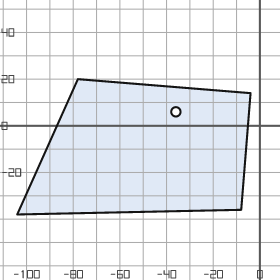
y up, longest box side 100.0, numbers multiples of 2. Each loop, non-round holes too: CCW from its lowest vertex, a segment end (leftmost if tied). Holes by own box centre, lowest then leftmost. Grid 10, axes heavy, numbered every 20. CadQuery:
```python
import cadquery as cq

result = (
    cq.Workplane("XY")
    .moveTo(-104.0, -38.0)
    .lineTo(-8.0, -36.0)
    .lineTo(-4.0, 14.0)
    .lineTo(-78.0, 20.0)
    .close()
    .moveTo(-36.0, 6.0)
    .circle(2.0)
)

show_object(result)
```